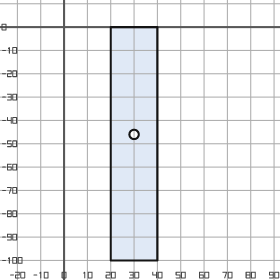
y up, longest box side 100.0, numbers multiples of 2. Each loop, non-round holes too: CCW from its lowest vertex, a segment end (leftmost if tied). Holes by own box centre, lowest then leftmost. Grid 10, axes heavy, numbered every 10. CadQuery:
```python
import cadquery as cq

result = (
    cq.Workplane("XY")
    .moveTo(20.0, -100.0)
    .lineTo(40.0, -100.0)
    .lineTo(40.0, 0.0)
    .lineTo(20.0, 0.0)
    .close()
    .moveTo(30.0, -46.0)
    .circle(2.0)
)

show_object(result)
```